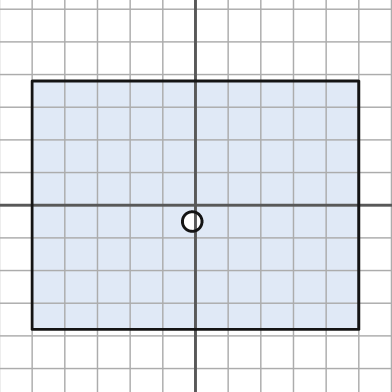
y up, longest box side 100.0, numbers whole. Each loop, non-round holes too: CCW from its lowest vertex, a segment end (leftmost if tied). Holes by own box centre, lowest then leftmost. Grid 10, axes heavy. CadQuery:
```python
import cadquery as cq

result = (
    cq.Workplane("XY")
    .moveTo(-50.0, -38.0)
    .lineTo(50.0, -38.0)
    .lineTo(50.0, 38.0)
    .lineTo(-50.0, 38.0)
    .close()
    .moveTo(-1.0, -5.0)
    .circle(3.0)
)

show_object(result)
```